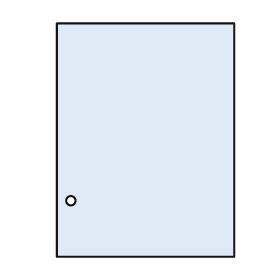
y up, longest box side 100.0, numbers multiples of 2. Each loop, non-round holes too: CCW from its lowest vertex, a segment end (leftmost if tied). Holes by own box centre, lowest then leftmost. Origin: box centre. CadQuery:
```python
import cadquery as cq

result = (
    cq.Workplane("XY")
    .moveTo(-38.0, -50.0)
    .lineTo(38.0, -50.0)
    .lineTo(38.0, 50.0)
    .lineTo(-38.0, 50.0)
    .close()
    .moveTo(-32.0, -26.0)
    .circle(2.0)
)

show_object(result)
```